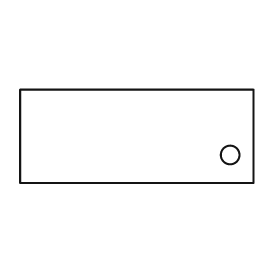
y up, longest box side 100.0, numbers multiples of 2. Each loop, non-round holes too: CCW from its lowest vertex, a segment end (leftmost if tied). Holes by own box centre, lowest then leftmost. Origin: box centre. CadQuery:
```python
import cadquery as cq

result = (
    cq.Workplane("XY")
    .moveTo(-50.0, -20.0)
    .lineTo(50.0, -20.0)
    .lineTo(50.0, 20.0)
    .lineTo(-50.0, 20.0)
    .close()
    .moveTo(40.0, -8.0)
    .circle(4.0)
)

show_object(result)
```